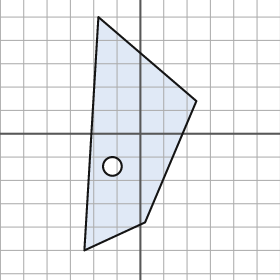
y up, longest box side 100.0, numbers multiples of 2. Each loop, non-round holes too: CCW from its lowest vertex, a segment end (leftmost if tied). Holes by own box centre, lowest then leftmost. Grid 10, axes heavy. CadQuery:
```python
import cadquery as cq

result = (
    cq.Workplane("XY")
    .moveTo(-24.0, -50.0)
    .lineTo(2.0, -38.0)
    .lineTo(24.0, 14.0)
    .lineTo(-18.0, 50.0)
    .close()
    .moveTo(-12.0, -14.0)
    .circle(4.0)
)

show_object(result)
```